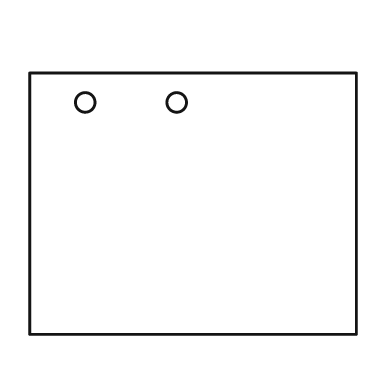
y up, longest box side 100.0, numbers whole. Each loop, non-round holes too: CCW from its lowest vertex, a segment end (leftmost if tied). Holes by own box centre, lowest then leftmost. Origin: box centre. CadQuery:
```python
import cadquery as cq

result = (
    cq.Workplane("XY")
    .moveTo(-50.0, -40.0)
    .lineTo(50.0, -40.0)
    .lineTo(50.0, 40.0)
    .lineTo(-50.0, 40.0)
    .close()
    .moveTo(-33.0, 31.0)
    .circle(3.0)
    .moveTo(-5.0, 31.0)
    .circle(3.0)
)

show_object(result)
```